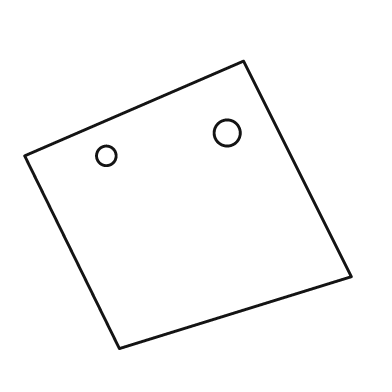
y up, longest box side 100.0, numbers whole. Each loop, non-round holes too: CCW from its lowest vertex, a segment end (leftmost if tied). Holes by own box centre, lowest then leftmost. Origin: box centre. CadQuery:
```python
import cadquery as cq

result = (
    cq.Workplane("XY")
    .moveTo(-21.0, -44.0)
    .lineTo(50.0, -22.0)
    .lineTo(17.0, 44.0)
    .lineTo(-50.0, 15.0)
    .close()
    .moveTo(-25.0, 15.0)
    .circle(3.0)
    .moveTo(12.0, 22.0)
    .circle(4.0)
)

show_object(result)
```